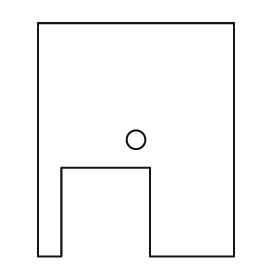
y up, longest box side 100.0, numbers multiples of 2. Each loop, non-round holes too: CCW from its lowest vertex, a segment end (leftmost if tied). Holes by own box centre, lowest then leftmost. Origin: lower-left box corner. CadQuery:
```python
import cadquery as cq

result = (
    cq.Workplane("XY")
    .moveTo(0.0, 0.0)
    .lineTo(10.0, 0.0)
    .lineTo(10.0, 38.0)
    .lineTo(48.0, 38.0)
    .lineTo(48.0, 0.0)
    .lineTo(84.0, 0.0)
    .lineTo(84.0, 100.0)
    .lineTo(0.0, 100.0)
    .close()
    .moveTo(42.0, 50.0)
    .circle(4.0)
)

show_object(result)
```